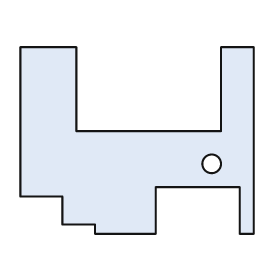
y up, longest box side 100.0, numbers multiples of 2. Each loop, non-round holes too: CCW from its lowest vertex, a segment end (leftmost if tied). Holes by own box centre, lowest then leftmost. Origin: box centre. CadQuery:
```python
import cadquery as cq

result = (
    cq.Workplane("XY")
    .moveTo(-18.0, -40.0)
    .lineTo(8.0, -40.0)
    .lineTo(8.0, -20.0)
    .lineTo(44.0, -20.0)
    .lineTo(44.0, -40.0)
    .lineTo(50.0, -40.0)
    .lineTo(50.0, 40.0)
    .lineTo(36.0, 40.0)
    .lineTo(36.0, 4.0)
    .lineTo(-26.0, 4.0)
    .lineTo(-26.0, 40.0)
    .lineTo(-50.0, 40.0)
    .lineTo(-50.0, -24.0)
    .lineTo(-32.0, -24.0)
    .lineTo(-32.0, -36.0)
    .lineTo(-18.0, -36.0)
    .close()
    .moveTo(32.0, -10.0)
    .circle(4.0)
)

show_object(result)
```